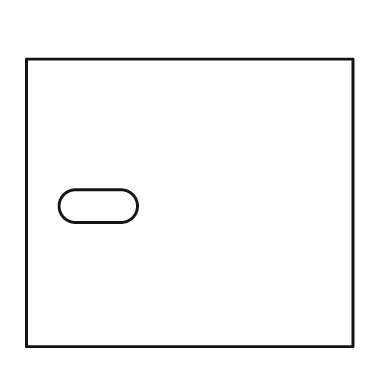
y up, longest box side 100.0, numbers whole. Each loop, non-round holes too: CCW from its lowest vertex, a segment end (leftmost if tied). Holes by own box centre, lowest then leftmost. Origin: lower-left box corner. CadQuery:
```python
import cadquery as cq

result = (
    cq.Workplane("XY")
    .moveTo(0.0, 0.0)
    .lineTo(100.0, 0.0)
    .lineTo(100.0, 88.0)
    .lineTo(0.0, 88.0)
    .close()
    .moveTo(15.0, 38.0)
    .lineTo(29.0, 38.0)
    .threePointArc((34.0, 43.0), (29.0, 48.0))
    .lineTo(15.0, 48.0)
    .threePointArc((10.0, 43.0), (15.0, 38.0))
    .close()
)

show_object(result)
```